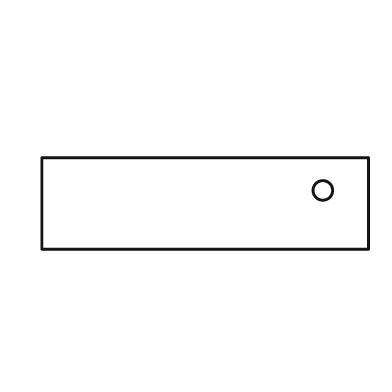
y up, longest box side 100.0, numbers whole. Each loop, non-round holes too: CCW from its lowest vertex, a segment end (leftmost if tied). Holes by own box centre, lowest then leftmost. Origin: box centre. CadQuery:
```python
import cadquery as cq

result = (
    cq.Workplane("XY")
    .moveTo(-50.0, -14.0)
    .lineTo(50.0, -14.0)
    .lineTo(50.0, 14.0)
    .lineTo(-50.0, 14.0)
    .close()
    .moveTo(36.0, 4.0)
    .circle(3.0)
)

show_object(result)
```